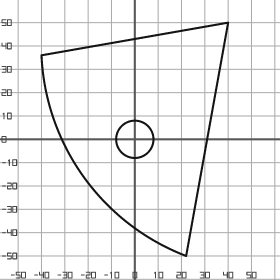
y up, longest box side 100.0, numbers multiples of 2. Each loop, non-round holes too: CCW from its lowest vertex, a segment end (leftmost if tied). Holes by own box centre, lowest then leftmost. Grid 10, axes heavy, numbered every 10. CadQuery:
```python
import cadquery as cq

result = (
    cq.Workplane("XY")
    .moveTo(22.0, -50.0)
    .lineTo(40.0, 50.0)
    .lineTo(-40.0, 36.0)
    .threePointArc((-22.0, -16.0), (22.0, -50.0))
    .close()
    .moveTo(0.0, 0.0)
    .circle(8.0)
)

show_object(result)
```